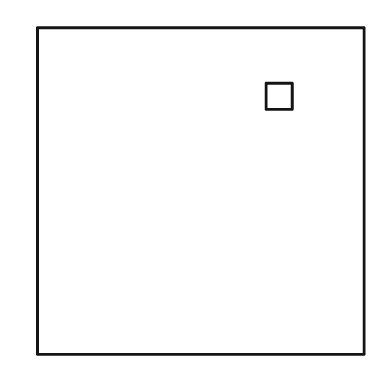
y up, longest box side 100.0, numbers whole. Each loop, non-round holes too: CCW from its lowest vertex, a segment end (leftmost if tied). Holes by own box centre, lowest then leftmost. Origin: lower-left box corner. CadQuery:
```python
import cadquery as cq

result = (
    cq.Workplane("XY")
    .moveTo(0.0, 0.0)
    .lineTo(100.0, 0.0)
    .lineTo(100.0, 100.0)
    .lineTo(0.0, 100.0)
    .close()
    .moveTo(70.0, 75.0)
    .lineTo(78.0, 75.0)
    .lineTo(78.0, 83.0)
    .lineTo(70.0, 83.0)
    .close()
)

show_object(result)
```